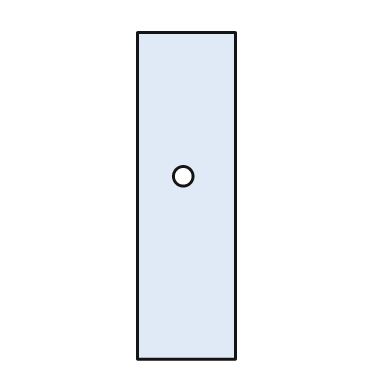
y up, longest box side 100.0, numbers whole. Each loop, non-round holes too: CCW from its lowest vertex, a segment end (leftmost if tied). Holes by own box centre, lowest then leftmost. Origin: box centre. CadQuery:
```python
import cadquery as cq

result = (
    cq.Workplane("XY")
    .moveTo(-15.0, -50.0)
    .lineTo(15.0, -50.0)
    .lineTo(15.0, 50.0)
    .lineTo(-15.0, 50.0)
    .close()
    .moveTo(-1.0, 6.0)
    .circle(3.0)
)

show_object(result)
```